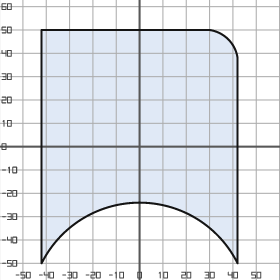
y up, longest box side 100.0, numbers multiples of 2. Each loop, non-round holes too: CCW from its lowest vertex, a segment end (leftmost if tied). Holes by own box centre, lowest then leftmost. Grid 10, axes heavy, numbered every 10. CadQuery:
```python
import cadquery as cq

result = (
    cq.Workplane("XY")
    .moveTo(-42.0, -50.0)
    .threePointArc((0.0, -24.0), (42.0, -50.0))
    .lineTo(42.0, 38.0)
    .threePointArc((38.0, 46.0), (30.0, 50.0))
    .lineTo(-42.0, 50.0)
    .close()
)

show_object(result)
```